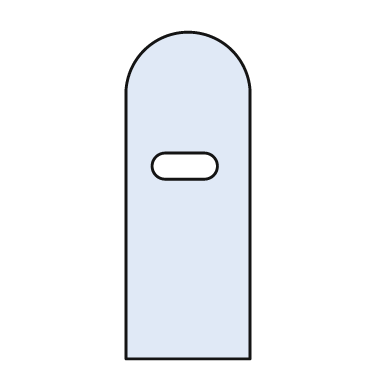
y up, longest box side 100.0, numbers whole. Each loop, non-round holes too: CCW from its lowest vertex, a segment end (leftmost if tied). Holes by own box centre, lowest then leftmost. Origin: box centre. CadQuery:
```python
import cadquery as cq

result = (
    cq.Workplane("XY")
    .moveTo(-19.0, -50.0)
    .lineTo(19.0, -50.0)
    .lineTo(19.0, 32.0)
    .threePointArc((0.0, 50.0), (-19.0, 32.0))
    .close()
    .moveTo(-7.0, 5.0)
    .lineTo(5.0, 5.0)
    .threePointArc((9.0, 9.0), (5.0, 13.0))
    .lineTo(-7.0, 13.0)
    .threePointArc((-11.0, 9.0), (-7.0, 5.0))
    .close()
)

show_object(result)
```